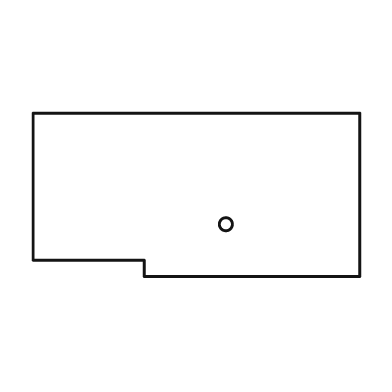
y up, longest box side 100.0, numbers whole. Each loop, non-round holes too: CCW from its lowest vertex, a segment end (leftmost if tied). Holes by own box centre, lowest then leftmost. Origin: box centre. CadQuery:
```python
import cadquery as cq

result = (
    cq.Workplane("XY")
    .moveTo(-16.0, -25.0)
    .lineTo(50.0, -25.0)
    .lineTo(50.0, 25.0)
    .lineTo(-50.0, 25.0)
    .lineTo(-50.0, -20.0)
    .lineTo(-16.0, -20.0)
    .close()
    .moveTo(9.0, -9.0)
    .circle(2.0)
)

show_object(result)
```